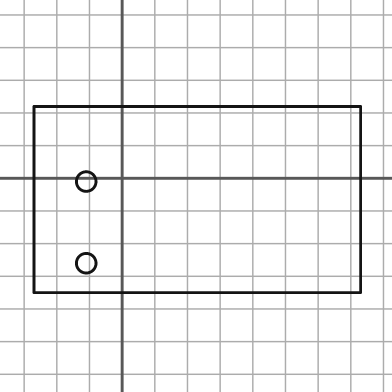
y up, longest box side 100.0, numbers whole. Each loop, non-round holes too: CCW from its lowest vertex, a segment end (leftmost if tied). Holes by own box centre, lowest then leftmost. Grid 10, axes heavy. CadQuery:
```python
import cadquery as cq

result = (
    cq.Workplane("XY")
    .moveTo(-27.0, -35.0)
    .lineTo(73.0, -35.0)
    .lineTo(73.0, 22.0)
    .lineTo(-27.0, 22.0)
    .close()
    .moveTo(-11.0, -26.0)
    .circle(3.0)
    .moveTo(-11.0, -1.0)
    .circle(3.0)
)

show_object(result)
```